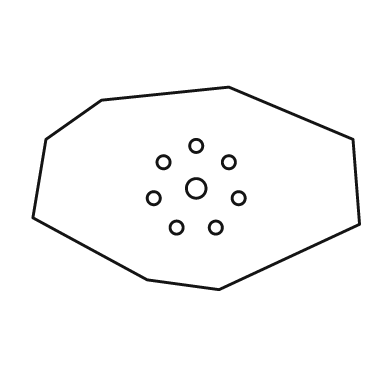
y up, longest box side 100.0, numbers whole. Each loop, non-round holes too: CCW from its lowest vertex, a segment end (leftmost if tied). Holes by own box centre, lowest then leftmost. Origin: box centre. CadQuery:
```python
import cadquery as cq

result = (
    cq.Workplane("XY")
    .moveTo(7.0, -31.0)
    .lineTo(50.0, -11.0)
    .lineTo(48.0, 15.0)
    .lineTo(10.0, 31.0)
    .lineTo(-29.0, 27.0)
    .lineTo(-46.0, 15.0)
    .lineTo(-50.0, -9.0)
    .lineTo(-15.0, -28.0)
    .close()
    .moveTo(-6.0, -12.0)
    .circle(2.0)
    .moveTo(6.0, -12.0)
    .circle(2.0)
    .moveTo(-13.0, -3.0)
    .circle(2.0)
    .moveTo(13.0, -3.0)
    .circle(2.0)
    .moveTo(0.0, 0.0)
    .circle(3.0)
    .moveTo(-10.0, 8.0)
    .circle(2.0)
    .moveTo(10.0, 8.0)
    .circle(2.0)
    .moveTo(0.0, 13.0)
    .circle(2.0)
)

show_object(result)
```